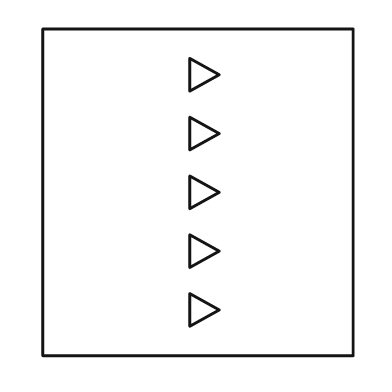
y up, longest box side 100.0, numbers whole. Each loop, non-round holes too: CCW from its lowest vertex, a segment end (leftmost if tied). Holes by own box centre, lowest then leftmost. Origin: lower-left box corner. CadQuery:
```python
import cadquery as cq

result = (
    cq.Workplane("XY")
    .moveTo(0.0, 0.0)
    .lineTo(95.0, 0.0)
    .lineTo(95.0, 100.0)
    .lineTo(0.0, 100.0)
    .close()
    .moveTo(45.0, 9.0)
    .lineTo(54.0, 14.0)
    .lineTo(45.0, 19.0)
    .close()
    .moveTo(45.0, 27.0)
    .lineTo(54.0, 32.0)
    .lineTo(45.0, 37.0)
    .close()
    .moveTo(45.0, 45.0)
    .lineTo(54.0, 50.0)
    .lineTo(45.0, 55.0)
    .close()
    .moveTo(45.0, 63.0)
    .lineTo(54.0, 68.0)
    .lineTo(45.0, 73.0)
    .close()
    .moveTo(45.0, 81.0)
    .lineTo(54.0, 86.0)
    .lineTo(45.0, 91.0)
    .close()
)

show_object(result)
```